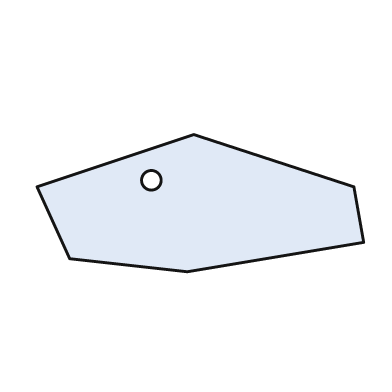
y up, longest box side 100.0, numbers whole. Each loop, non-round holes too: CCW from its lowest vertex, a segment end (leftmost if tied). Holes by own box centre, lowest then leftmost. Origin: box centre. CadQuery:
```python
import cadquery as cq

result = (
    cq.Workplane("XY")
    .moveTo(-4.0, -21.0)
    .lineTo(50.0, -12.0)
    .lineTo(47.0, 5.0)
    .lineTo(-2.0, 21.0)
    .lineTo(-50.0, 5.0)
    .lineTo(-40.0, -17.0)
    .close()
    .moveTo(-15.0, 7.0)
    .circle(3.0)
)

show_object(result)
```